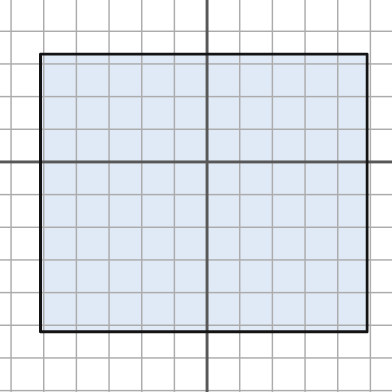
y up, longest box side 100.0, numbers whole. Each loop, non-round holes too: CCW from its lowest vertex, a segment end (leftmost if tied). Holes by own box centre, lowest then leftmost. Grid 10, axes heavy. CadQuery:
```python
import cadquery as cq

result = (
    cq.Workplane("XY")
    .moveTo(-51.0, -52.0)
    .lineTo(49.0, -52.0)
    .lineTo(49.0, 33.0)
    .lineTo(-51.0, 33.0)
    .close()
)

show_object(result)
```